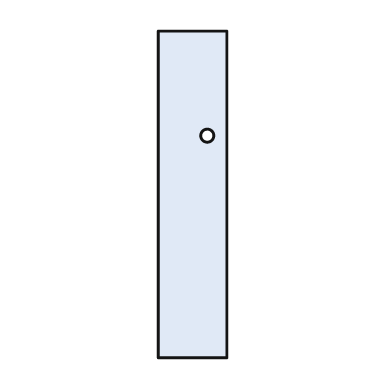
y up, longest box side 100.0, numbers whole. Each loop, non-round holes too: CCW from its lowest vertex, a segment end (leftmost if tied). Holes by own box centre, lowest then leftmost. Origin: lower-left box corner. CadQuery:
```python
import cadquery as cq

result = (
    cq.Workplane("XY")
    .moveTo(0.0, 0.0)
    .lineTo(21.0, 0.0)
    .lineTo(21.0, 100.0)
    .lineTo(0.0, 100.0)
    .close()
    .moveTo(15.0, 68.0)
    .circle(2.0)
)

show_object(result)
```